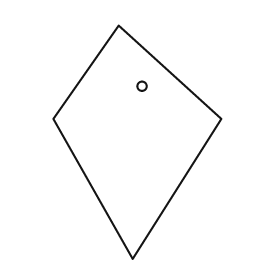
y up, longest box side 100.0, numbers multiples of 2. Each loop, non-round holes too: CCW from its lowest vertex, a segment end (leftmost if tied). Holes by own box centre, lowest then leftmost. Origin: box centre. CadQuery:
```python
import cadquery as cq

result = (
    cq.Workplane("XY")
    .moveTo(-2.0, -50.0)
    .lineTo(36.0, 10.0)
    .lineTo(-8.0, 50.0)
    .lineTo(-36.0, 10.0)
    .close()
    .moveTo(2.0, 24.0)
    .circle(2.0)
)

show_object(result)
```